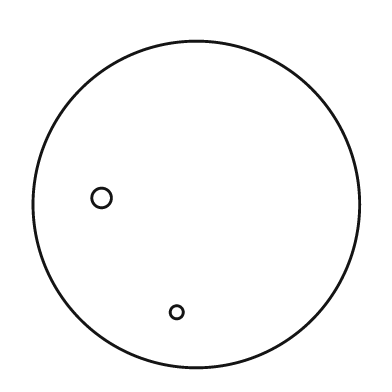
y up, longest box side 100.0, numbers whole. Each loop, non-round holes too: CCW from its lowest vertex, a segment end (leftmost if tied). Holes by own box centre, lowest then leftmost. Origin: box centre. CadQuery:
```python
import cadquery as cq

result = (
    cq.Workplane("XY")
    .moveTo(0.0, 0.0)
    .circle(50.0)
    .moveTo(-6.0, -33.0)
    .circle(2.0)
    .moveTo(-29.0, 2.0)
    .circle(3.0)
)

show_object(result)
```